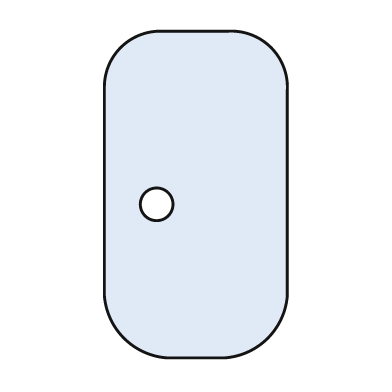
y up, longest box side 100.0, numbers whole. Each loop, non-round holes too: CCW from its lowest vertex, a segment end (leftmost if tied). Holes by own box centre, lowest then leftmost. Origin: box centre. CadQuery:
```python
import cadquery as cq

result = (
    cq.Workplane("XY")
    .moveTo(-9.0, -50.0)
    .lineTo(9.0, -50.0)
    .threePointArc((22.0, -44.0), (28.0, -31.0))
    .lineTo(28.0, 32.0)
    .threePointArc((23.0, 45.0), (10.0, 50.0))
    .lineTo(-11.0, 50.0)
    .threePointArc((-23.0, 45.0), (-28.0, 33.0))
    .lineTo(-28.0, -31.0)
    .threePointArc((-22.0, -44.0), (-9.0, -50.0))
    .close()
    .moveTo(-12.0, -3.0)
    .circle(5.0)
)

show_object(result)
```